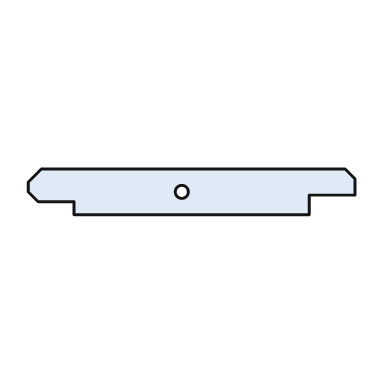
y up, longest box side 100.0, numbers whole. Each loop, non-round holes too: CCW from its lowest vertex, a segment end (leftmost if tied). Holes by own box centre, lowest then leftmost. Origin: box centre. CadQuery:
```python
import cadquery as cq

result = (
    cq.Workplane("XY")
    .moveTo(-36.0, -7.0)
    .lineTo(36.0, -7.0)
    .lineTo(36.0, -1.0)
    .lineTo(50.0, -1.0)
    .lineTo(50.0, 4.0)
    .lineTo(47.0, 7.0)
    .lineTo(-46.0, 7.0)
    .lineTo(-50.0, 3.0)
    .lineTo(-50.0, 0.0)
    .lineTo(-47.0, -3.0)
    .lineTo(-36.0, -3.0)
    .close()
    .moveTo(-3.0, 0.0)
    .circle(2.0)
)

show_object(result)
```